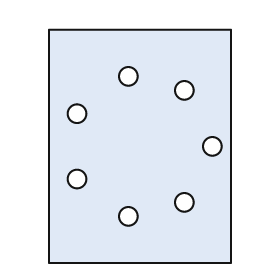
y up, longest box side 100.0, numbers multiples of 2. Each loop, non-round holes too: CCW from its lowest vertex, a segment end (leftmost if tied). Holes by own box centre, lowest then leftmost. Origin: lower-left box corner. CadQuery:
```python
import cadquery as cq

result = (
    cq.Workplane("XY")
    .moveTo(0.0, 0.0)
    .lineTo(78.0, 0.0)
    .lineTo(78.0, 100.0)
    .lineTo(0.0, 100.0)
    .close()
    .moveTo(34.0, 20.0)
    .circle(4.0)
    .moveTo(58.0, 26.0)
    .circle(4.0)
    .moveTo(12.0, 36.0)
    .circle(4.0)
    .moveTo(70.0, 50.0)
    .circle(4.0)
    .moveTo(12.0, 64.0)
    .circle(4.0)
    .moveTo(58.0, 74.0)
    .circle(4.0)
    .moveTo(34.0, 80.0)
    .circle(4.0)
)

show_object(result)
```